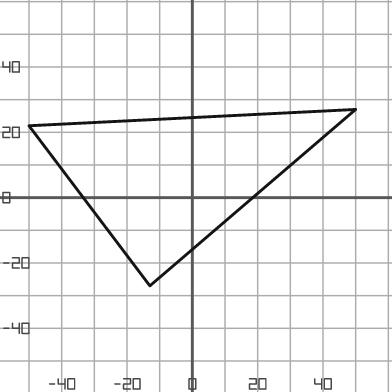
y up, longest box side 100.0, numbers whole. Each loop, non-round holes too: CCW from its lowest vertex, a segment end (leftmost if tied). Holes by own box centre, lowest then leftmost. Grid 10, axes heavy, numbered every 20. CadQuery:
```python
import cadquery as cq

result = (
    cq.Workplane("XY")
    .moveTo(-13.0, -27.0)
    .lineTo(50.0, 27.0)
    .lineTo(-50.0, 22.0)
    .close()
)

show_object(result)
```